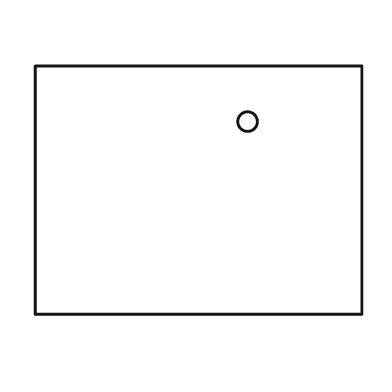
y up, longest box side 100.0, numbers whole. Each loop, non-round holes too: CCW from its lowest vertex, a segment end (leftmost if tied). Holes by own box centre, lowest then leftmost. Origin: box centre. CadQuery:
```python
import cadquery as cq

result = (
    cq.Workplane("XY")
    .moveTo(-50.0, -38.0)
    .lineTo(50.0, -38.0)
    .lineTo(50.0, 38.0)
    .lineTo(-50.0, 38.0)
    .close()
    .moveTo(15.0, 21.0)
    .circle(3.0)
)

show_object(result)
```